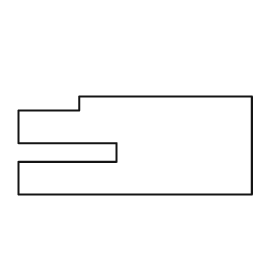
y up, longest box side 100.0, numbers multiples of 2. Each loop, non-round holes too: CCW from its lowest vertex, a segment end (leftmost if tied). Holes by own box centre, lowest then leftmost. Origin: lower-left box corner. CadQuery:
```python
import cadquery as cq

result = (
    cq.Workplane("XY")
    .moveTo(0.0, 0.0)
    .lineTo(100.0, 0.0)
    .lineTo(100.0, 42.0)
    .lineTo(26.0, 42.0)
    .lineTo(26.0, 36.0)
    .lineTo(0.0, 36.0)
    .lineTo(0.0, 22.0)
    .lineTo(42.0, 22.0)
    .lineTo(42.0, 14.0)
    .lineTo(0.0, 14.0)
    .close()
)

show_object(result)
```